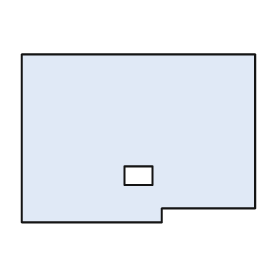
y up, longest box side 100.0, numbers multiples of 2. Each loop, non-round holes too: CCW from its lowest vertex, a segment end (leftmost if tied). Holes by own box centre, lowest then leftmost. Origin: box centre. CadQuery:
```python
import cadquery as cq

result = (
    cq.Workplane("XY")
    .moveTo(-50.0, -36.0)
    .lineTo(10.0, -36.0)
    .lineTo(10.0, -30.0)
    .lineTo(50.0, -30.0)
    .lineTo(50.0, 36.0)
    .lineTo(-50.0, 36.0)
    .close()
    .moveTo(-6.0, -20.0)
    .lineTo(6.0, -20.0)
    .lineTo(6.0, -12.0)
    .lineTo(-6.0, -12.0)
    .close()
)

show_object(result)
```